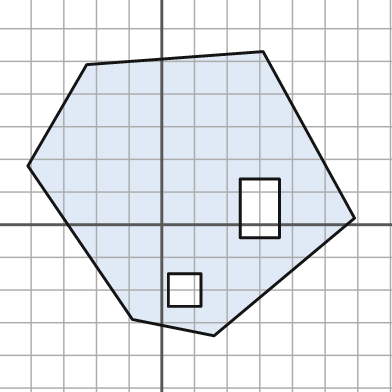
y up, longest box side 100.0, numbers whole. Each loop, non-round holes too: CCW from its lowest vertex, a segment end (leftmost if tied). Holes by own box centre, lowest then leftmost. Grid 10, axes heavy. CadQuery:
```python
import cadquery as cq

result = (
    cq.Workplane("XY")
    .moveTo(16.0, -34.0)
    .lineTo(59.0, 2.0)
    .lineTo(31.0, 53.0)
    .lineTo(-23.0, 49.0)
    .lineTo(-41.0, 18.0)
    .lineTo(-9.0, -29.0)
    .close()
    .moveTo(2.0, -25.0)
    .lineTo(12.0, -25.0)
    .lineTo(12.0, -15.0)
    .lineTo(2.0, -15.0)
    .close()
    .moveTo(24.0, -4.0)
    .lineTo(36.0, -4.0)
    .lineTo(36.0, 14.0)
    .lineTo(24.0, 14.0)
    .close()
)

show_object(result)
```